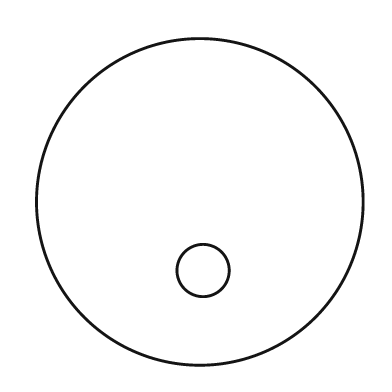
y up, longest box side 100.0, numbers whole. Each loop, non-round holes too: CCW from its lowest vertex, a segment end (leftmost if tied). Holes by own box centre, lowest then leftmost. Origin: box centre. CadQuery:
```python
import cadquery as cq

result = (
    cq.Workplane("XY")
    .moveTo(0.0, 0.0)
    .circle(50.0)
    .moveTo(1.0, -21.0)
    .circle(8.0)
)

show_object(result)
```